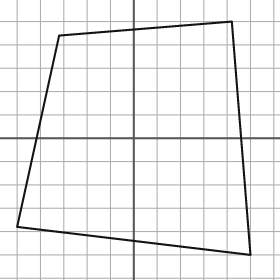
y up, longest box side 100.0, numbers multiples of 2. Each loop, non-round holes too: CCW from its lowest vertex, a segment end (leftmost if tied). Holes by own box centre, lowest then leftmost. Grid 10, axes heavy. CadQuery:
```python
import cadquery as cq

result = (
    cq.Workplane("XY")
    .moveTo(50.0, -50.0)
    .lineTo(42.0, 50.0)
    .lineTo(-32.0, 44.0)
    .lineTo(-50.0, -38.0)
    .close()
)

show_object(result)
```